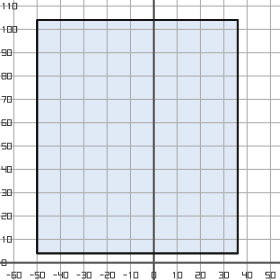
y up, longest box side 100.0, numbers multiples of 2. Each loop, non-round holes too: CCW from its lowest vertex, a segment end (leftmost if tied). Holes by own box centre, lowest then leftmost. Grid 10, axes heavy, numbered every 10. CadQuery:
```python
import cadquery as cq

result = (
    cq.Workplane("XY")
    .moveTo(-50.0, 4.0)
    .lineTo(36.0, 4.0)
    .lineTo(36.0, 104.0)
    .lineTo(-50.0, 104.0)
    .close()
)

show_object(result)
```